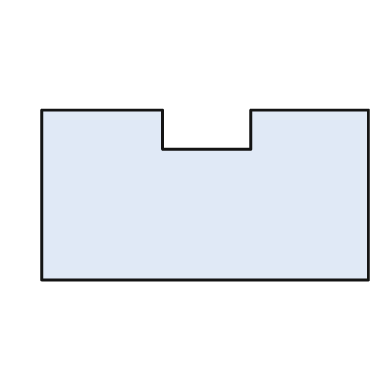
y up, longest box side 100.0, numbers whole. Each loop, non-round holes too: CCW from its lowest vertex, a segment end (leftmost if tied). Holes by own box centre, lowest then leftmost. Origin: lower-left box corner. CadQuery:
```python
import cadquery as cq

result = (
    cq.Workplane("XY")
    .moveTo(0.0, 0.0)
    .lineTo(100.0, 0.0)
    .lineTo(100.0, 52.0)
    .lineTo(64.0, 52.0)
    .lineTo(64.0, 40.0)
    .lineTo(37.0, 40.0)
    .lineTo(37.0, 52.0)
    .lineTo(0.0, 52.0)
    .close()
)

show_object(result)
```